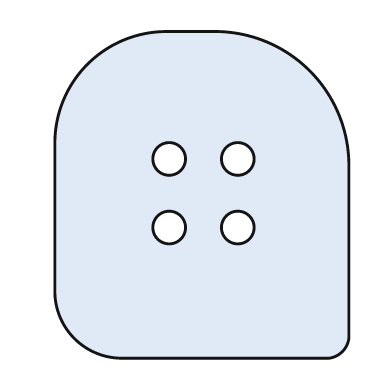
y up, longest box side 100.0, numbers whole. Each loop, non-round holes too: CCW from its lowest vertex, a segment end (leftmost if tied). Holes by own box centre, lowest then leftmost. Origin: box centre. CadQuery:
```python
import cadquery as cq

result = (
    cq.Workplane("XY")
    .moveTo(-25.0, -50.0)
    .lineTo(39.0, -50.0)
    .threePointArc((43.0, -48.0), (45.0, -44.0))
    .lineTo(45.0, 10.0)
    .threePointArc((33.0, 38.0), (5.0, 50.0))
    .lineTo(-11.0, 50.0)
    .threePointArc((-35.0, 40.0), (-45.0, 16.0))
    .lineTo(-45.0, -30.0)
    .threePointArc((-39.0, -44.0), (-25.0, -50.0))
    .close()
    .moveTo(-10.0, -10.0)
    .circle(5.0)
    .moveTo(11.0, -10.0)
    .circle(5.0)
    .moveTo(-10.0, 11.0)
    .circle(5.0)
    .moveTo(11.0, 11.0)
    .circle(5.0)
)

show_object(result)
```